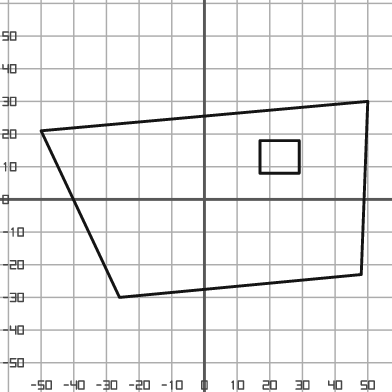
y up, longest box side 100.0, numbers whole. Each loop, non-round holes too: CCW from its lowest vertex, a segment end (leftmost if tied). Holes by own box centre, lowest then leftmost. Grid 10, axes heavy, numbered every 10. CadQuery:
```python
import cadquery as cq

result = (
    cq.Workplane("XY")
    .moveTo(-26.0, -30.0)
    .lineTo(48.0, -23.0)
    .lineTo(50.0, 30.0)
    .lineTo(-50.0, 21.0)
    .close()
    .moveTo(17.0, 8.0)
    .lineTo(29.0, 8.0)
    .lineTo(29.0, 18.0)
    .lineTo(17.0, 18.0)
    .close()
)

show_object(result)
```